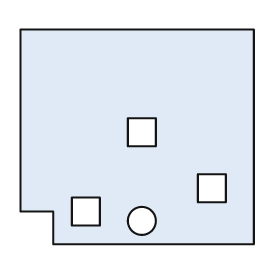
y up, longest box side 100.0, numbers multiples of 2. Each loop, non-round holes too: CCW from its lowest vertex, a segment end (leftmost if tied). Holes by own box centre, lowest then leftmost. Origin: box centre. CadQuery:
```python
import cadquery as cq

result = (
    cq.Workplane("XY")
    .moveTo(-36.0, -46.0)
    .lineTo(50.0, -46.0)
    .lineTo(50.0, 46.0)
    .lineTo(-50.0, 46.0)
    .lineTo(-50.0, -32.0)
    .lineTo(-36.0, -32.0)
    .close()
    .moveTo(2.0, -36.0)
    .circle(6.0)
    .moveTo(-28.0, -38.0)
    .lineTo(-16.0, -38.0)
    .lineTo(-16.0, -26.0)
    .lineTo(-28.0, -26.0)
    .close()
    .moveTo(26.0, -28.0)
    .lineTo(38.0, -28.0)
    .lineTo(38.0, -16.0)
    .lineTo(26.0, -16.0)
    .close()
    .moveTo(-4.0, -4.0)
    .lineTo(8.0, -4.0)
    .lineTo(8.0, 8.0)
    .lineTo(-4.0, 8.0)
    .close()
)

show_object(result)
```